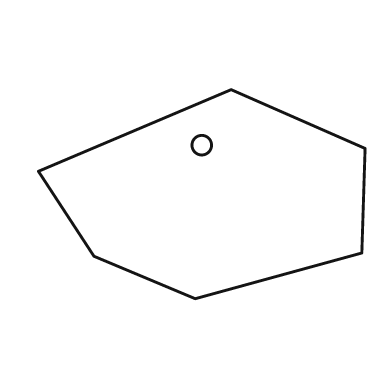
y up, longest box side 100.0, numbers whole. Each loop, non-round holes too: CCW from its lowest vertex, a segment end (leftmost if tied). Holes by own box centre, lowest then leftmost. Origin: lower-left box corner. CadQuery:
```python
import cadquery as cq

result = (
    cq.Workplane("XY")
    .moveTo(48.0, 0.0)
    .lineTo(99.0, 14.0)
    .lineTo(100.0, 46.0)
    .lineTo(59.0, 64.0)
    .lineTo(0.0, 39.0)
    .lineTo(17.0, 13.0)
    .close()
    .moveTo(50.0, 47.0)
    .circle(3.0)
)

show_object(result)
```